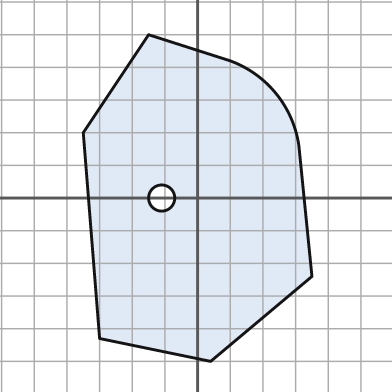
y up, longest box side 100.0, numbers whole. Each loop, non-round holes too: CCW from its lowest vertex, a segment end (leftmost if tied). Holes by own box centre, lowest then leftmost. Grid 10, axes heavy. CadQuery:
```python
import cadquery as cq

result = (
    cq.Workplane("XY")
    .moveTo(4.0, -50.0)
    .lineTo(35.0, -24.0)
    .lineTo(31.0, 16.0)
    .threePointArc((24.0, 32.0), (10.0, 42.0))
    .lineTo(-15.0, 50.0)
    .lineTo(-35.0, 20.0)
    .lineTo(-30.0, -43.0)
    .close()
    .moveTo(-11.0, 0.0)
    .circle(4.0)
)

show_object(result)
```